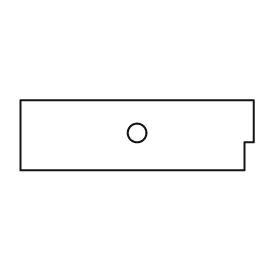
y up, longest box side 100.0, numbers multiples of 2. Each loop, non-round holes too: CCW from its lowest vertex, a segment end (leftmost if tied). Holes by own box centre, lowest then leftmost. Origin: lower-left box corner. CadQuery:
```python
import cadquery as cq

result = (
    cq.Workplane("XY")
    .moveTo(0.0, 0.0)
    .lineTo(96.0, 0.0)
    .lineTo(96.0, 12.0)
    .lineTo(100.0, 12.0)
    .lineTo(100.0, 30.0)
    .lineTo(0.0, 30.0)
    .close()
    .moveTo(50.0, 16.0)
    .circle(4.0)
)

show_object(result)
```